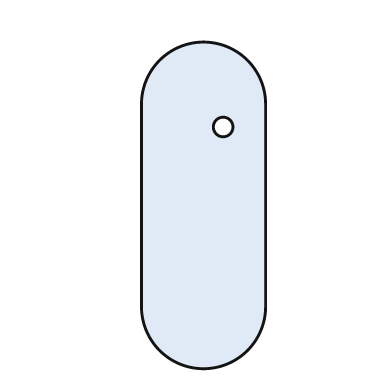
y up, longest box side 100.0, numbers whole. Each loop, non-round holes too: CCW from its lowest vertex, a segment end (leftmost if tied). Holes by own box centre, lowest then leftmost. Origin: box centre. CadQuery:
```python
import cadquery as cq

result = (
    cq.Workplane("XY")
    .moveTo(-19.0, -31.0)
    .threePointArc((0.0, -50.0), (19.0, -31.0))
    .lineTo(19.0, 31.0)
    .threePointArc((0.0, 50.0), (-19.0, 31.0))
    .close()
    .moveTo(6.0, 24.0)
    .circle(3.0)
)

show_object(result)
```